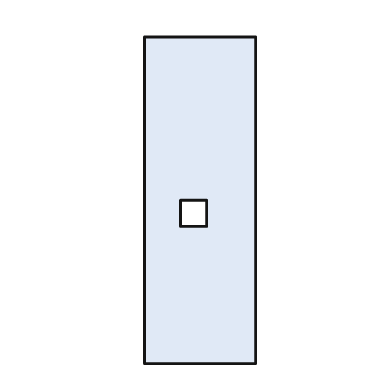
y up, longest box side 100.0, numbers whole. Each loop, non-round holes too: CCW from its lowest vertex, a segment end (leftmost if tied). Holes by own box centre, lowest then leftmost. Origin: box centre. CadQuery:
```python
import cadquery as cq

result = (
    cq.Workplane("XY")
    .moveTo(-17.0, -50.0)
    .lineTo(17.0, -50.0)
    .lineTo(17.0, 50.0)
    .lineTo(-17.0, 50.0)
    .close()
    .moveTo(-6.0, -8.0)
    .lineTo(2.0, -8.0)
    .lineTo(2.0, 0.0)
    .lineTo(-6.0, 0.0)
    .close()
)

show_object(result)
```